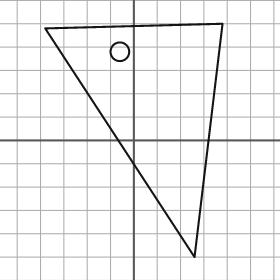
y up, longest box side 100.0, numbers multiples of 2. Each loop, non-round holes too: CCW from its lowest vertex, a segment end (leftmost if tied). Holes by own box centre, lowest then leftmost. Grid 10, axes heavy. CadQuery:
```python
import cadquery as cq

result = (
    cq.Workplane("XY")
    .moveTo(26.0, -50.0)
    .lineTo(38.0, 50.0)
    .lineTo(-38.0, 48.0)
    .close()
    .moveTo(-6.0, 38.0)
    .circle(4.0)
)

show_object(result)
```